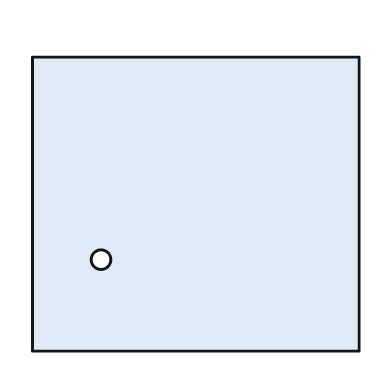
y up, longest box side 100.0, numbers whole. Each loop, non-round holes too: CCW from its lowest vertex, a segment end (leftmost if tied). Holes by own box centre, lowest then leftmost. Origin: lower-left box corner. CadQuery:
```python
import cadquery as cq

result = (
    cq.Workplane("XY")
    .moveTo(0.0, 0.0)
    .lineTo(100.0, 0.0)
    .lineTo(100.0, 90.0)
    .lineTo(0.0, 90.0)
    .close()
    .moveTo(21.0, 28.0)
    .circle(3.0)
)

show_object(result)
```